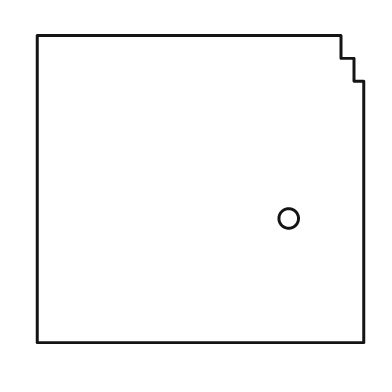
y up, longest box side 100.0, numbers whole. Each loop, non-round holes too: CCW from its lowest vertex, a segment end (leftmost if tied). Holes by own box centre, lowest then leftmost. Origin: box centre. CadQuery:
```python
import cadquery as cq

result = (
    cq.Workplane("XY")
    .moveTo(-50.0, -47.0)
    .lineTo(50.0, -47.0)
    .lineTo(50.0, 33.0)
    .lineTo(47.0, 33.0)
    .lineTo(47.0, 40.0)
    .lineTo(43.0, 40.0)
    .lineTo(43.0, 47.0)
    .lineTo(-50.0, 47.0)
    .close()
    .moveTo(27.0, -9.0)
    .circle(3.0)
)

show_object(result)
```